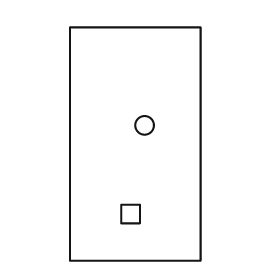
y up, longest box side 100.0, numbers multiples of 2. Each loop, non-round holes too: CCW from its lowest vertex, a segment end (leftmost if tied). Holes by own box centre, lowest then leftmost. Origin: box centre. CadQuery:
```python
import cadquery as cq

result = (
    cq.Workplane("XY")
    .moveTo(-28.0, -50.0)
    .lineTo(28.0, -50.0)
    .lineTo(28.0, 50.0)
    .lineTo(-28.0, 50.0)
    .close()
    .moveTo(-6.0, -34.0)
    .lineTo(2.0, -34.0)
    .lineTo(2.0, -26.0)
    .lineTo(-6.0, -26.0)
    .close()
    .moveTo(4.0, 8.0)
    .circle(4.0)
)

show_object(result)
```